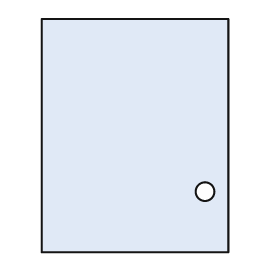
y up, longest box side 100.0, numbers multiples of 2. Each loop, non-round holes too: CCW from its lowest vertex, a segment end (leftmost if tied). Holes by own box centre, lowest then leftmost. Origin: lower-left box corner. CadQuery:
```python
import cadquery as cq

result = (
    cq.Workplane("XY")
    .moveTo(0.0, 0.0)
    .lineTo(80.0, 0.0)
    .lineTo(80.0, 100.0)
    .lineTo(0.0, 100.0)
    .close()
    .moveTo(70.0, 26.0)
    .circle(4.0)
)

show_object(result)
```